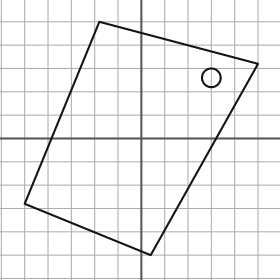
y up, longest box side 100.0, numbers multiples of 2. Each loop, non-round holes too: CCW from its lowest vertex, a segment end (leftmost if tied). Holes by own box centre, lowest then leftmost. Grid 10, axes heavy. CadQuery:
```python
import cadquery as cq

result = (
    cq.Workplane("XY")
    .moveTo(4.0, -50.0)
    .lineTo(50.0, 32.0)
    .lineTo(-18.0, 50.0)
    .lineTo(-50.0, -28.0)
    .close()
    .moveTo(30.0, 26.0)
    .circle(4.0)
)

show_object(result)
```